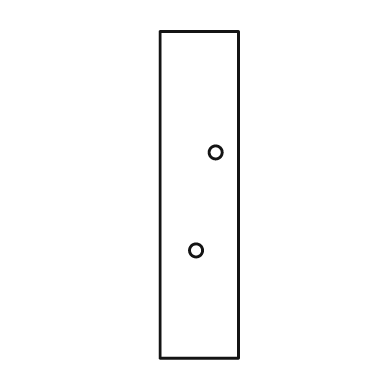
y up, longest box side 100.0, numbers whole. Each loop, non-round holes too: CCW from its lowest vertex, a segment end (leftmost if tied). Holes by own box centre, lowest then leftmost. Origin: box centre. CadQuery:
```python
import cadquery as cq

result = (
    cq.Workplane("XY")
    .moveTo(-12.0, -50.0)
    .lineTo(12.0, -50.0)
    .lineTo(12.0, 50.0)
    .lineTo(-12.0, 50.0)
    .close()
    .moveTo(-1.0, -17.0)
    .circle(2.0)
    .moveTo(5.0, 13.0)
    .circle(2.0)
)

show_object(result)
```